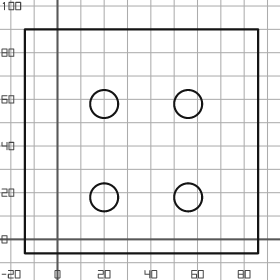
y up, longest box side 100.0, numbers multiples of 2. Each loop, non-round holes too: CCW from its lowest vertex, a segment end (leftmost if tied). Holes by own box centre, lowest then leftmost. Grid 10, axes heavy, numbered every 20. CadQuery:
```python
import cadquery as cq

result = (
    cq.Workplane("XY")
    .moveTo(-14.0, -6.0)
    .lineTo(86.0, -6.0)
    .lineTo(86.0, 90.0)
    .lineTo(-14.0, 90.0)
    .close()
    .moveTo(20.0, 18.0)
    .circle(6.0)
    .moveTo(56.0, 18.0)
    .circle(6.0)
    .moveTo(20.0, 58.0)
    .circle(6.0)
    .moveTo(56.0, 58.0)
    .circle(6.0)
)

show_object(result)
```